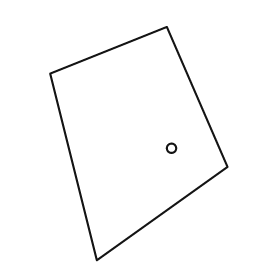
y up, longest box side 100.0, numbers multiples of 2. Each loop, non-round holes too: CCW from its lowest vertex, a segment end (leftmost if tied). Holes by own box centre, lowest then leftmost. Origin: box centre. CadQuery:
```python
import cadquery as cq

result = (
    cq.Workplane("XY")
    .moveTo(-18.0, -50.0)
    .lineTo(38.0, -10.0)
    .lineTo(12.0, 50.0)
    .lineTo(-38.0, 30.0)
    .close()
    .moveTo(14.0, -2.0)
    .circle(2.0)
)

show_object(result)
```